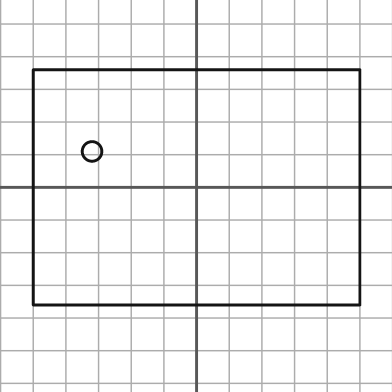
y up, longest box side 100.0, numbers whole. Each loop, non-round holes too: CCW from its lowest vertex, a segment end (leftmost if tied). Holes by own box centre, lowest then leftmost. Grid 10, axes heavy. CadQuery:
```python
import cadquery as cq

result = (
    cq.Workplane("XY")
    .moveTo(-50.0, -36.0)
    .lineTo(50.0, -36.0)
    .lineTo(50.0, 36.0)
    .lineTo(-50.0, 36.0)
    .close()
    .moveTo(-32.0, 11.0)
    .circle(3.0)
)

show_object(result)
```